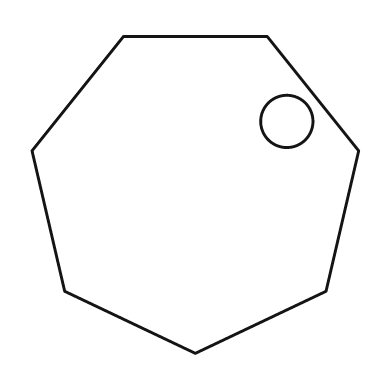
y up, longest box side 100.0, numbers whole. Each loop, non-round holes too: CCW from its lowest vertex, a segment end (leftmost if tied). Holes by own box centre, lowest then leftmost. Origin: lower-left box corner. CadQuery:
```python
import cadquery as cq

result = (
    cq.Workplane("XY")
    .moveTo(50.0, 0.0)
    .lineTo(90.0, 19.0)
    .lineTo(100.0, 62.0)
    .lineTo(72.0, 97.0)
    .lineTo(28.0, 97.0)
    .lineTo(0.0, 62.0)
    .lineTo(10.0, 19.0)
    .close()
    .moveTo(78.0, 71.0)
    .circle(8.0)
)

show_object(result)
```